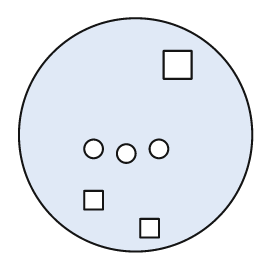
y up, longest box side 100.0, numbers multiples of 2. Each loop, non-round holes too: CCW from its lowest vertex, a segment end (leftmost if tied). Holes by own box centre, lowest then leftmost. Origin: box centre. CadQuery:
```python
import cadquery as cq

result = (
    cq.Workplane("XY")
    .moveTo(0.0, 0.0)
    .circle(50.0)
    .moveTo(2.0, -44.0)
    .lineTo(10.0, -44.0)
    .lineTo(10.0, -36.0)
    .lineTo(2.0, -36.0)
    .close()
    .moveTo(-22.0, -32.0)
    .lineTo(-14.0, -32.0)
    .lineTo(-14.0, -24.0)
    .lineTo(-22.0, -24.0)
    .close()
    .moveTo(-4.0, -8.0)
    .circle(4.0)
    .moveTo(-18.0, -6.0)
    .circle(4.0)
    .moveTo(10.0, -6.0)
    .circle(4.0)
    .moveTo(12.0, 24.0)
    .lineTo(24.0, 24.0)
    .lineTo(24.0, 36.0)
    .lineTo(12.0, 36.0)
    .close()
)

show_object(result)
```